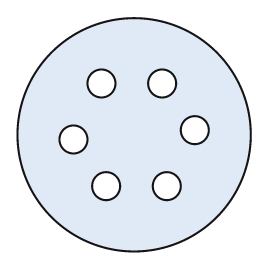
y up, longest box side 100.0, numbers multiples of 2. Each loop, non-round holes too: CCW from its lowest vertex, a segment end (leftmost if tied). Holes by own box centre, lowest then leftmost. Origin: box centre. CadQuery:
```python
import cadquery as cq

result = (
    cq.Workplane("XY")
    .moveTo(0.0, 0.0)
    .circle(50.0)
    .moveTo(-12.0, -22.0)
    .circle(6.0)
    .moveTo(14.0, -22.0)
    .circle(6.0)
    .moveTo(-26.0, -2.0)
    .circle(6.0)
    .moveTo(26.0, 2.0)
    .circle(6.0)
    .moveTo(-14.0, 22.0)
    .circle(6.0)
    .moveTo(12.0, 22.0)
    .circle(6.0)
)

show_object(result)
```